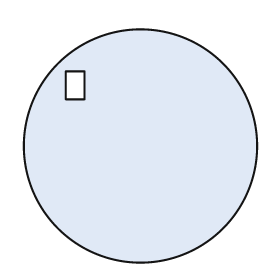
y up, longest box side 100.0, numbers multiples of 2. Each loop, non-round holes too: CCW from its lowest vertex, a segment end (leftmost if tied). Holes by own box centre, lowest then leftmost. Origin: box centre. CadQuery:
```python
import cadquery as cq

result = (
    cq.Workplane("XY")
    .moveTo(0.0, 0.0)
    .circle(50.0)
    .moveTo(-32.0, 20.0)
    .lineTo(-24.0, 20.0)
    .lineTo(-24.0, 32.0)
    .lineTo(-32.0, 32.0)
    .close()
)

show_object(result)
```